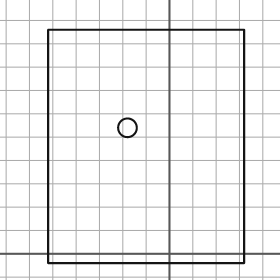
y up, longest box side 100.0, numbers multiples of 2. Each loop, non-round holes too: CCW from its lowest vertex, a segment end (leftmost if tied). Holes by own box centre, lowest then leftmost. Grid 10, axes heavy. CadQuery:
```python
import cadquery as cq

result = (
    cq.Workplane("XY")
    .moveTo(-52.0, -4.0)
    .lineTo(32.0, -4.0)
    .lineTo(32.0, 96.0)
    .lineTo(-52.0, 96.0)
    .close()
    .moveTo(-18.0, 54.0)
    .circle(4.0)
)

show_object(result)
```